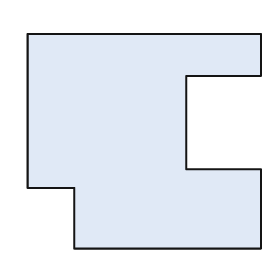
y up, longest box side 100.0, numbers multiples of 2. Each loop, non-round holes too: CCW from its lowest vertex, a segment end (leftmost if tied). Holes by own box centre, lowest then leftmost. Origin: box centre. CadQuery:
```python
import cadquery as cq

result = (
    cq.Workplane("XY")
    .moveTo(-30.0, -46.0)
    .lineTo(50.0, -46.0)
    .lineTo(50.0, -12.0)
    .lineTo(18.0, -12.0)
    .lineTo(18.0, 28.0)
    .lineTo(50.0, 28.0)
    .lineTo(50.0, 46.0)
    .lineTo(-50.0, 46.0)
    .lineTo(-50.0, -20.0)
    .lineTo(-30.0, -20.0)
    .close()
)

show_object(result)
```